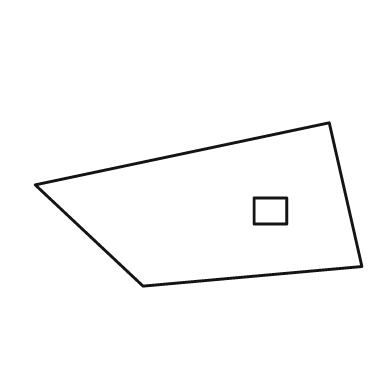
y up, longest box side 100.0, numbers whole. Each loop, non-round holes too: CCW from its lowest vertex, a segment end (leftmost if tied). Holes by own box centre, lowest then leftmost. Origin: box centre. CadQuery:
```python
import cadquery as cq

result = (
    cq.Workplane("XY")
    .moveTo(-17.0, -25.0)
    .lineTo(50.0, -19.0)
    .lineTo(40.0, 25.0)
    .lineTo(-50.0, 6.0)
    .close()
    .moveTo(17.0, -6.0)
    .lineTo(27.0, -6.0)
    .lineTo(27.0, 2.0)
    .lineTo(17.0, 2.0)
    .close()
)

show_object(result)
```